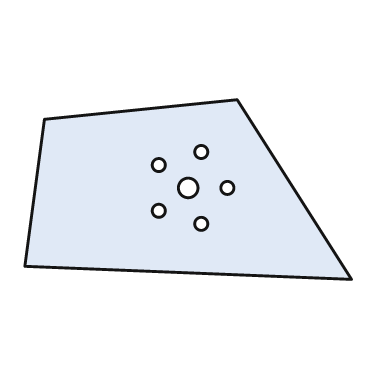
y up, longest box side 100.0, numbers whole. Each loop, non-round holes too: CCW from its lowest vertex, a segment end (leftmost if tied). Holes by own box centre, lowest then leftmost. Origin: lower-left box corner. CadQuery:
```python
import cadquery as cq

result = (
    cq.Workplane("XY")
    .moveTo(100.0, 0.0)
    .lineTo(65.0, 55.0)
    .lineTo(6.0, 49.0)
    .lineTo(0.0, 4.0)
    .close()
    .moveTo(54.0, 17.0)
    .circle(2.0)
    .moveTo(41.0, 21.0)
    .circle(2.0)
    .moveTo(50.0, 28.0)
    .circle(3.0)
    .moveTo(62.0, 28.0)
    .circle(2.0)
    .moveTo(41.0, 35.0)
    .circle(2.0)
    .moveTo(54.0, 39.0)
    .circle(2.0)
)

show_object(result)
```